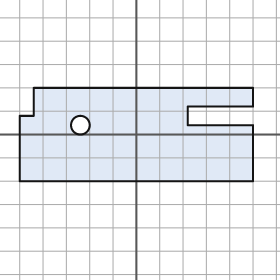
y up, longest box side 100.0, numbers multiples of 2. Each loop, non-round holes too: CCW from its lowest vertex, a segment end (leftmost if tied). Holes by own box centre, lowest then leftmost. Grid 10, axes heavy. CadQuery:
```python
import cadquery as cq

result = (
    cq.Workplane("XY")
    .moveTo(-50.0, -20.0)
    .lineTo(50.0, -20.0)
    .lineTo(50.0, 4.0)
    .lineTo(22.0, 4.0)
    .lineTo(22.0, 12.0)
    .lineTo(50.0, 12.0)
    .lineTo(50.0, 20.0)
    .lineTo(-44.0, 20.0)
    .lineTo(-44.0, 8.0)
    .lineTo(-50.0, 8.0)
    .close()
    .moveTo(-24.0, 4.0)
    .circle(4.0)
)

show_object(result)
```